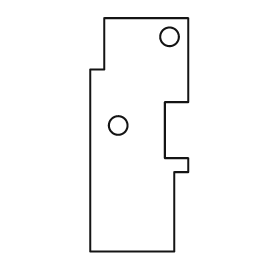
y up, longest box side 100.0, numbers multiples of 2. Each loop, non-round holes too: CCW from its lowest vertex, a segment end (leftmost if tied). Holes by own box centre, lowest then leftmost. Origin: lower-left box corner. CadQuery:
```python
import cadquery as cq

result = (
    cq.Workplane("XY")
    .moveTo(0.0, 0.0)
    .lineTo(36.0, 0.0)
    .lineTo(36.0, 34.0)
    .lineTo(42.0, 34.0)
    .lineTo(42.0, 40.0)
    .lineTo(32.0, 40.0)
    .lineTo(32.0, 64.0)
    .lineTo(42.0, 64.0)
    .lineTo(42.0, 100.0)
    .lineTo(6.0, 100.0)
    .lineTo(6.0, 78.0)
    .lineTo(0.0, 78.0)
    .close()
    .moveTo(12.0, 54.0)
    .circle(4.0)
    .moveTo(34.0, 92.0)
    .circle(4.0)
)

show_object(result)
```